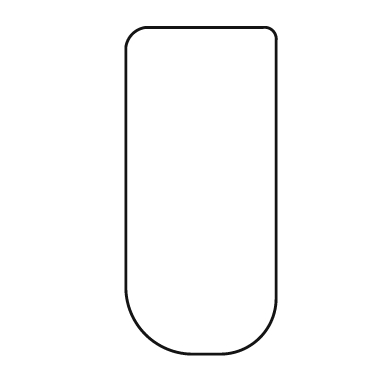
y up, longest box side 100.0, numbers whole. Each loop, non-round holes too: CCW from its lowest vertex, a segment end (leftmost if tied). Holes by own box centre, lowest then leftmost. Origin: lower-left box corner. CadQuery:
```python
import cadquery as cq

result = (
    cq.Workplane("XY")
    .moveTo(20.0, 0.0)
    .lineTo(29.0, 0.0)
    .threePointArc((41.0, 5.0), (46.0, 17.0))
    .lineTo(46.0, 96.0)
    .threePointArc((45.0, 99.0), (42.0, 100.0))
    .lineTo(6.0, 100.0)
    .threePointArc((2.0, 98.0), (0.0, 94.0))
    .lineTo(0.0, 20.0)
    .threePointArc((6.0, 6.0), (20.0, 0.0))
    .close()
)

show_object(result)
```